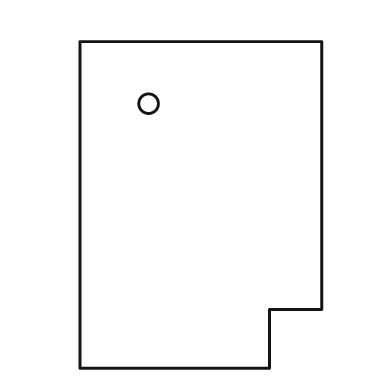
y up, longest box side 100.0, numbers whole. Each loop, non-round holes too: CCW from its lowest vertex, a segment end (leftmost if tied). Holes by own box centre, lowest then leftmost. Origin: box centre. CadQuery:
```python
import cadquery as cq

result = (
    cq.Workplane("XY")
    .moveTo(-37.0, -50.0)
    .lineTo(21.0, -50.0)
    .lineTo(21.0, -32.0)
    .lineTo(37.0, -32.0)
    .lineTo(37.0, 50.0)
    .lineTo(-37.0, 50.0)
    .close()
    .moveTo(-16.0, 31.0)
    .circle(3.0)
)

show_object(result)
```